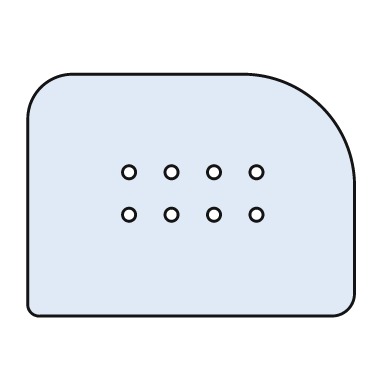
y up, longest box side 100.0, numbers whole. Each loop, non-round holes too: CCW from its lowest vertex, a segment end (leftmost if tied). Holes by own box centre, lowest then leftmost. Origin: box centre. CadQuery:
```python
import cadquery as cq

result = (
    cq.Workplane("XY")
    .moveTo(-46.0, -37.0)
    .lineTo(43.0, -37.0)
    .threePointArc((48.0, -35.0), (50.0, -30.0))
    .lineTo(50.0, 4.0)
    .threePointArc((40.0, 27.0), (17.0, 37.0))
    .lineTo(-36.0, 37.0)
    .threePointArc((-46.0, 33.0), (-50.0, 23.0))
    .lineTo(-50.0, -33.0)
    .threePointArc((-49.0, -36.0), (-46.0, -37.0))
    .close()
    .moveTo(-19.0, -6.0)
    .circle(2.0)
    .moveTo(-6.0, -6.0)
    .circle(2.0)
    .moveTo(7.0, -6.0)
    .circle(2.0)
    .moveTo(20.0, -6.0)
    .circle(2.0)
    .moveTo(-19.0, 7.0)
    .circle(2.0)
    .moveTo(-6.0, 7.0)
    .circle(2.0)
    .moveTo(7.0, 7.0)
    .circle(2.0)
    .moveTo(20.0, 7.0)
    .circle(2.0)
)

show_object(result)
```